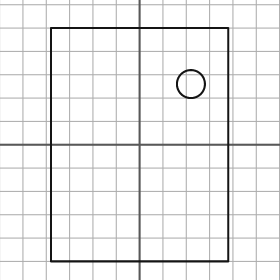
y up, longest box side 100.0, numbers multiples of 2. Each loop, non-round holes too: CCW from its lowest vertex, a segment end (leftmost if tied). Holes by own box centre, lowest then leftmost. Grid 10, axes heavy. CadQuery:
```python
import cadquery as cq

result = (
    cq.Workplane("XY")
    .moveTo(-38.0, -50.0)
    .lineTo(38.0, -50.0)
    .lineTo(38.0, 50.0)
    .lineTo(-38.0, 50.0)
    .close()
    .moveTo(22.0, 26.0)
    .circle(6.0)
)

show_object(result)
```